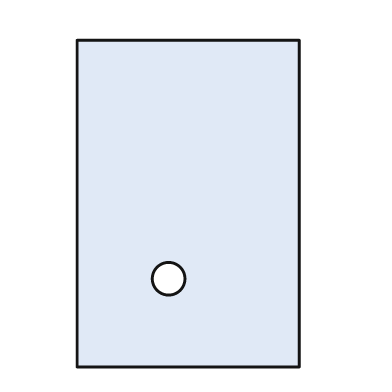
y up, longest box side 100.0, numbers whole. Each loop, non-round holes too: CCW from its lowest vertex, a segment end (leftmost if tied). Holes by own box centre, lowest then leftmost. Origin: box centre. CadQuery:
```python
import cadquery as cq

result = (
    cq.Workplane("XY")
    .moveTo(-34.0, -50.0)
    .lineTo(34.0, -50.0)
    .lineTo(34.0, 50.0)
    .lineTo(-34.0, 50.0)
    .close()
    .moveTo(-6.0, -23.0)
    .circle(5.0)
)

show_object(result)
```